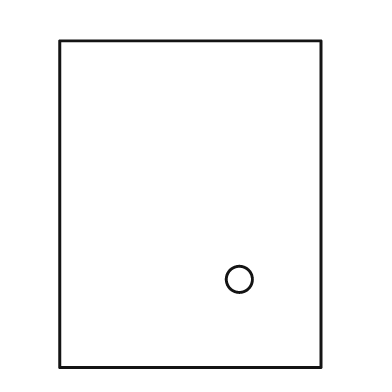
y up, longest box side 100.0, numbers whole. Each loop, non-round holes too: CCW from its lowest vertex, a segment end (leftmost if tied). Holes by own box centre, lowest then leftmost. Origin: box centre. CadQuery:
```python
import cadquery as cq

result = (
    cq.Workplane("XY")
    .moveTo(-40.0, -50.0)
    .lineTo(40.0, -50.0)
    .lineTo(40.0, 50.0)
    .lineTo(-40.0, 50.0)
    .close()
    .moveTo(15.0, -23.0)
    .circle(4.0)
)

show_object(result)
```